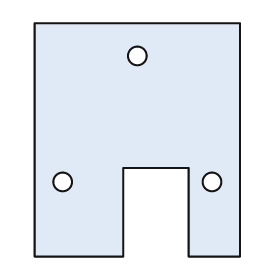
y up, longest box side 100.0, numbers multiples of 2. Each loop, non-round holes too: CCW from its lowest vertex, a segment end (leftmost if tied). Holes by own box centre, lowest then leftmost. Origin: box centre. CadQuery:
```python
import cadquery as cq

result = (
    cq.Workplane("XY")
    .moveTo(-44.0, -50.0)
    .lineTo(-6.0, -50.0)
    .lineTo(-6.0, -12.0)
    .lineTo(22.0, -12.0)
    .lineTo(22.0, -50.0)
    .lineTo(44.0, -50.0)
    .lineTo(44.0, 50.0)
    .lineTo(-44.0, 50.0)
    .close()
    .moveTo(-32.0, -18.0)
    .circle(4.0)
    .moveTo(32.0, -18.0)
    .circle(4.0)
    .moveTo(0.0, 36.0)
    .circle(4.0)
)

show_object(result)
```